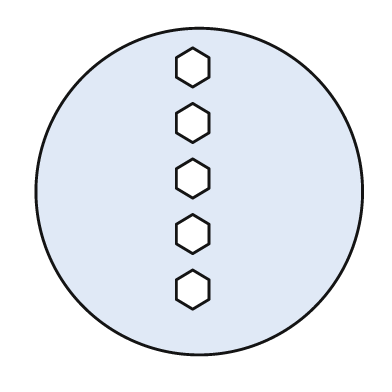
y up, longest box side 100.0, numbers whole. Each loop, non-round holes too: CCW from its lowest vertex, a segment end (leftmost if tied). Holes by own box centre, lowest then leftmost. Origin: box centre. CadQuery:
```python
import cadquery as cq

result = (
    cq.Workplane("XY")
    .moveTo(0.0, 0.0)
    .circle(50.0)
    .moveTo(-2.0, -36.0)
    .lineTo(3.0, -33.0)
    .lineTo(3.0, -27.0)
    .lineTo(-2.0, -24.0)
    .lineTo(-7.0, -27.0)
    .lineTo(-7.0, -33.0)
    .close()
    .moveTo(-2.0, -19.0)
    .lineTo(3.0, -16.0)
    .lineTo(3.0, -10.0)
    .lineTo(-2.0, -7.0)
    .lineTo(-7.0, -10.0)
    .lineTo(-7.0, -16.0)
    .close()
    .moveTo(-2.0, -2.0)
    .lineTo(3.0, 1.0)
    .lineTo(3.0, 7.0)
    .lineTo(-2.0, 10.0)
    .lineTo(-7.0, 7.0)
    .lineTo(-7.0, 1.0)
    .close()
    .moveTo(-2.0, 15.0)
    .lineTo(3.0, 18.0)
    .lineTo(3.0, 24.0)
    .lineTo(-2.0, 27.0)
    .lineTo(-7.0, 24.0)
    .lineTo(-7.0, 18.0)
    .close()
    .moveTo(-2.0, 32.0)
    .lineTo(3.0, 35.0)
    .lineTo(3.0, 41.0)
    .lineTo(-2.0, 44.0)
    .lineTo(-7.0, 41.0)
    .lineTo(-7.0, 35.0)
    .close()
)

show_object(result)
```